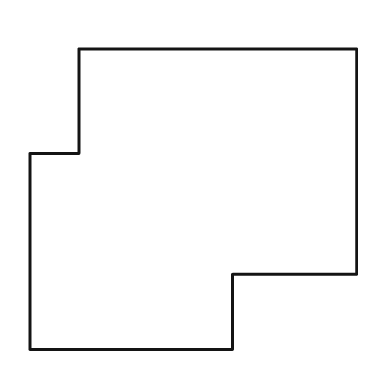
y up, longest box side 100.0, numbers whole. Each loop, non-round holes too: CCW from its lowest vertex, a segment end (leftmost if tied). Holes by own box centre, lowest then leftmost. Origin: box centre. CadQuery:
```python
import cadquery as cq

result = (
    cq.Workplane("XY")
    .moveTo(-50.0, -46.0)
    .lineTo(12.0, -46.0)
    .lineTo(12.0, -23.0)
    .lineTo(50.0, -23.0)
    .lineTo(50.0, 46.0)
    .lineTo(-35.0, 46.0)
    .lineTo(-35.0, 14.0)
    .lineTo(-50.0, 14.0)
    .close()
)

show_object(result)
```